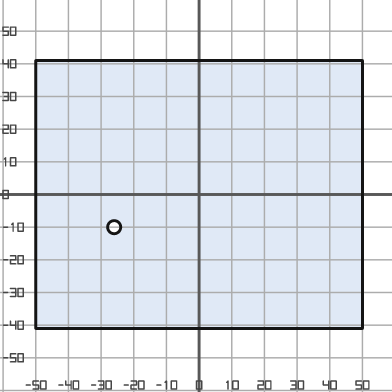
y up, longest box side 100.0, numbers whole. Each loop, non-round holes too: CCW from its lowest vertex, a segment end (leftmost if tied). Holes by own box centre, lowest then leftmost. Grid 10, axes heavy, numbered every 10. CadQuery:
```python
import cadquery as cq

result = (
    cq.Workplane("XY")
    .moveTo(-50.0, -41.0)
    .lineTo(50.0, -41.0)
    .lineTo(50.0, 41.0)
    .lineTo(-50.0, 41.0)
    .close()
    .moveTo(-26.0, -10.0)
    .circle(2.0)
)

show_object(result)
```